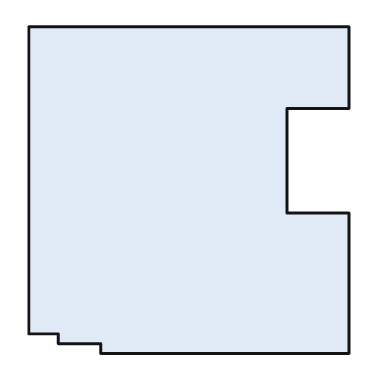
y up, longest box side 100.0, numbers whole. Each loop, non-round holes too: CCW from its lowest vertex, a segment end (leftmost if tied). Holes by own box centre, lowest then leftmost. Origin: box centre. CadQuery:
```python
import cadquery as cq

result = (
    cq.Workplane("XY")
    .moveTo(-27.0, -50.0)
    .lineTo(49.0, -50.0)
    .lineTo(49.0, -7.0)
    .lineTo(30.0, -7.0)
    .lineTo(30.0, 25.0)
    .lineTo(49.0, 25.0)
    .lineTo(49.0, 50.0)
    .lineTo(-49.0, 50.0)
    .lineTo(-49.0, -44.0)
    .lineTo(-40.0, -44.0)
    .lineTo(-40.0, -47.0)
    .lineTo(-27.0, -47.0)
    .close()
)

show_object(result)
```